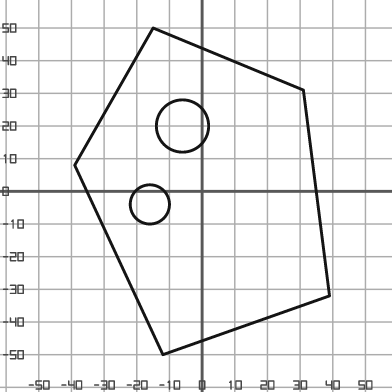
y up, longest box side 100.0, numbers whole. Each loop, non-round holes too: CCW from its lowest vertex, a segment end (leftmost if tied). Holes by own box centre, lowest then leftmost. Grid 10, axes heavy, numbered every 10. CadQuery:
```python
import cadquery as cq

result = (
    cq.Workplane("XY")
    .moveTo(-12.0, -50.0)
    .lineTo(39.0, -32.0)
    .lineTo(31.0, 31.0)
    .lineTo(-15.0, 50.0)
    .lineTo(-39.0, 8.0)
    .close()
    .moveTo(-16.0, -4.0)
    .circle(6.0)
    .moveTo(-6.0, 20.0)
    .circle(8.0)
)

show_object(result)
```